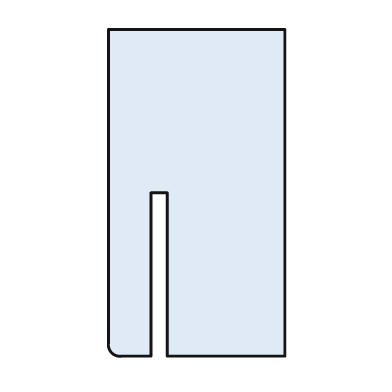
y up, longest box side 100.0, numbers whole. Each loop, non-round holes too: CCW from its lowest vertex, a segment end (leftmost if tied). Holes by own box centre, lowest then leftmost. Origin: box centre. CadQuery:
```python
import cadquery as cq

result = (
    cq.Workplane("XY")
    .moveTo(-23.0, -50.0)
    .lineTo(-14.0, -50.0)
    .lineTo(-14.0, 0.0)
    .lineTo(-9.0, 0.0)
    .lineTo(-9.0, -50.0)
    .lineTo(27.0, -50.0)
    .lineTo(27.0, 50.0)
    .lineTo(-27.0, 50.0)
    .lineTo(-27.0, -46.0)
    .threePointArc((-26.0, -49.0), (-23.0, -50.0))
    .close()
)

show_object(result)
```